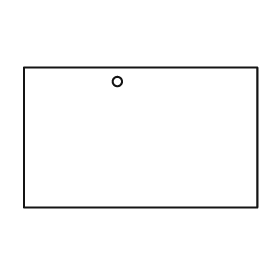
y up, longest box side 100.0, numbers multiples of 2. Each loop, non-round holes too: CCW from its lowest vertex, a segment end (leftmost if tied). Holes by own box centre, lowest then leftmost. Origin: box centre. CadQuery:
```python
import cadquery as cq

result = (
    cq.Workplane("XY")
    .moveTo(-50.0, -30.0)
    .lineTo(50.0, -30.0)
    .lineTo(50.0, 30.0)
    .lineTo(-50.0, 30.0)
    .close()
    .moveTo(-10.0, 24.0)
    .circle(2.0)
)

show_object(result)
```